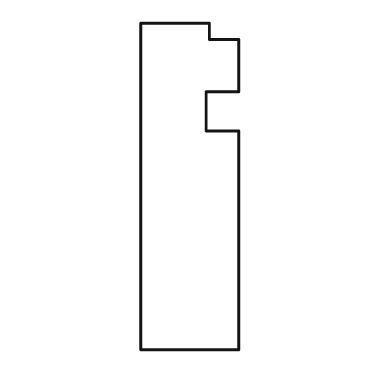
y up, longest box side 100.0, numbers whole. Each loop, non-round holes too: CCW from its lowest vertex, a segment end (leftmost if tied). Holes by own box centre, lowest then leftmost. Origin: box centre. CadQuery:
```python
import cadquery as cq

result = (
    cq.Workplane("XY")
    .moveTo(-15.0, -50.0)
    .lineTo(15.0, -50.0)
    .lineTo(15.0, 17.0)
    .lineTo(5.0, 17.0)
    .lineTo(5.0, 29.0)
    .lineTo(15.0, 29.0)
    .lineTo(15.0, 45.0)
    .lineTo(6.0, 45.0)
    .lineTo(6.0, 50.0)
    .lineTo(-15.0, 50.0)
    .close()
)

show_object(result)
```